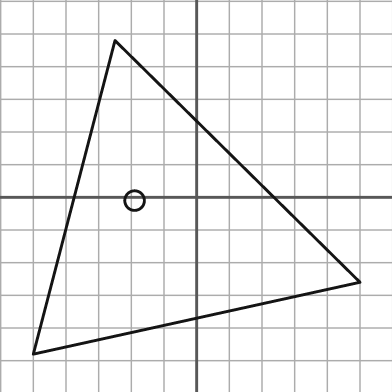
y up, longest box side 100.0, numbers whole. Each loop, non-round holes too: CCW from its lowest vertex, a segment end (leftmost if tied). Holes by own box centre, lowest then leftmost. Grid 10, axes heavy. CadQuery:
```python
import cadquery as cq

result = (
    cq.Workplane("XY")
    .moveTo(-50.0, -48.0)
    .lineTo(50.0, -26.0)
    .lineTo(-25.0, 48.0)
    .close()
    .moveTo(-19.0, -1.0)
    .circle(3.0)
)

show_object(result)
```